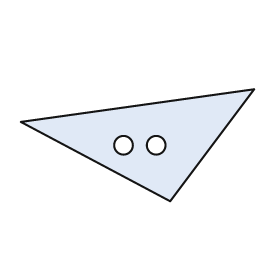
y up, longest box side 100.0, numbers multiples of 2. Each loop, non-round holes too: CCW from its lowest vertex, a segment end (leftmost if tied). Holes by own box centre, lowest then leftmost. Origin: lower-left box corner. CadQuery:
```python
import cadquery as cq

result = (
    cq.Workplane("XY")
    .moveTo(64.0, 0.0)
    .lineTo(100.0, 48.0)
    .lineTo(0.0, 34.0)
    .close()
    .moveTo(44.0, 24.0)
    .circle(4.0)
    .moveTo(58.0, 24.0)
    .circle(4.0)
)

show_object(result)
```